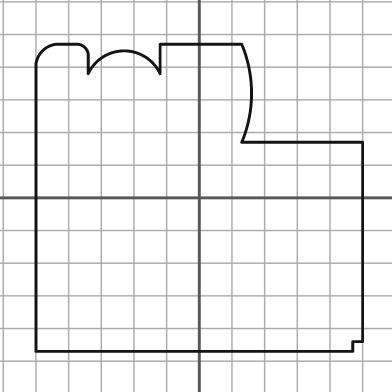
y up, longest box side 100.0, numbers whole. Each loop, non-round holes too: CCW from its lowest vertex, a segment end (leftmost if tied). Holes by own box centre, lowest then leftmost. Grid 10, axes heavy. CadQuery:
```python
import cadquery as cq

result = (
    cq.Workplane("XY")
    .moveTo(-50.0, -47.0)
    .lineTo(47.0, -47.0)
    .lineTo(47.0, -44.0)
    .lineTo(50.0, -44.0)
    .lineTo(50.0, 17.0)
    .lineTo(13.0, 17.0)
    .threePointArc((16.0, 32.0), (13.0, 47.0))
    .lineTo(-12.0, 47.0)
    .lineTo(-12.0, 38.0)
    .threePointArc((-23.0, 45.0), (-34.0, 38.0))
    .lineTo(-34.0, 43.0)
    .threePointArc((-35.0, 46.0), (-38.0, 47.0))
    .lineTo(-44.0, 47.0)
    .threePointArc((-48.0, 45.0), (-50.0, 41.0))
    .close()
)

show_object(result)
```